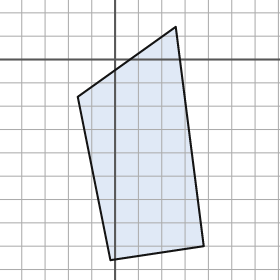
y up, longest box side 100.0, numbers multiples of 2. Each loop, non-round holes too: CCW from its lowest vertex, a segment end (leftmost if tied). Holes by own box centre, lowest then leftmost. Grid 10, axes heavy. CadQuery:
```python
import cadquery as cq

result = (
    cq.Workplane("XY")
    .moveTo(-2.0, -86.0)
    .lineTo(38.0, -80.0)
    .lineTo(26.0, 14.0)
    .lineTo(-16.0, -16.0)
    .close()
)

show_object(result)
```